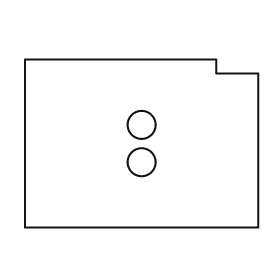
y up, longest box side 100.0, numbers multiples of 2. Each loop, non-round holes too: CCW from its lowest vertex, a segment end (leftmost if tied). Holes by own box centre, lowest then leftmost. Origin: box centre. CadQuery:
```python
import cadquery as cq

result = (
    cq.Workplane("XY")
    .moveTo(-50.0, -36.0)
    .lineTo(50.0, -36.0)
    .lineTo(50.0, 30.0)
    .lineTo(32.0, 30.0)
    .lineTo(32.0, 36.0)
    .lineTo(-50.0, 36.0)
    .close()
    .moveTo(0.0, -8.0)
    .circle(6.0)
    .moveTo(0.0, 8.0)
    .circle(6.0)
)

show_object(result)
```